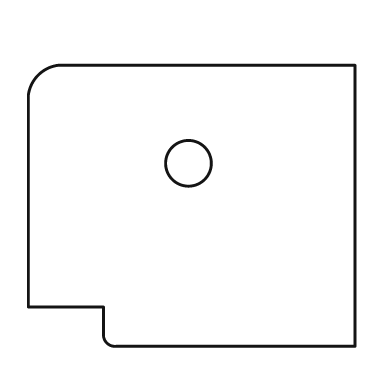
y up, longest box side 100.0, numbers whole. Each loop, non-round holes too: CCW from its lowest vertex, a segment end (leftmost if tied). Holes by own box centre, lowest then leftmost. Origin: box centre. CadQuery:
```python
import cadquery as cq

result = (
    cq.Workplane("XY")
    .moveTo(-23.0, -43.0)
    .lineTo(50.0, -43.0)
    .lineTo(50.0, 43.0)
    .lineTo(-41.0, 43.0)
    .threePointArc((-47.0, 40.0), (-50.0, 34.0))
    .lineTo(-50.0, -31.0)
    .lineTo(-27.0, -31.0)
    .lineTo(-27.0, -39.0)
    .threePointArc((-26.0, -42.0), (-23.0, -43.0))
    .close()
    .moveTo(-1.0, 13.0)
    .circle(7.0)
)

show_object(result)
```